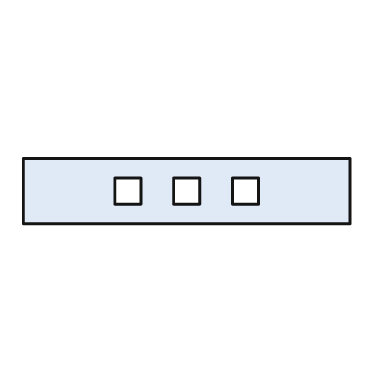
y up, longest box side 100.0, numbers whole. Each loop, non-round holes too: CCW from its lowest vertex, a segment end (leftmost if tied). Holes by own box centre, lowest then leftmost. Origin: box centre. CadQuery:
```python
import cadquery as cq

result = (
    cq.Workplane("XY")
    .moveTo(-50.0, -10.0)
    .lineTo(50.0, -10.0)
    .lineTo(50.0, 10.0)
    .lineTo(-50.0, 10.0)
    .close()
    .moveTo(-22.0, -4.0)
    .lineTo(-14.0, -4.0)
    .lineTo(-14.0, 4.0)
    .lineTo(-22.0, 4.0)
    .close()
    .moveTo(-4.0, -4.0)
    .lineTo(4.0, -4.0)
    .lineTo(4.0, 4.0)
    .lineTo(-4.0, 4.0)
    .close()
    .moveTo(14.0, -4.0)
    .lineTo(22.0, -4.0)
    .lineTo(22.0, 4.0)
    .lineTo(14.0, 4.0)
    .close()
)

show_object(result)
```